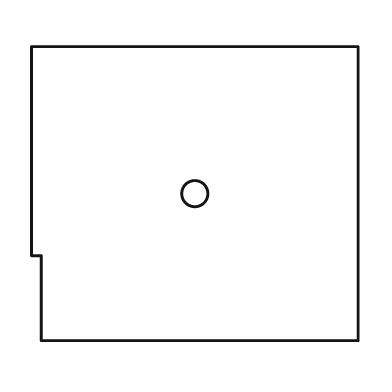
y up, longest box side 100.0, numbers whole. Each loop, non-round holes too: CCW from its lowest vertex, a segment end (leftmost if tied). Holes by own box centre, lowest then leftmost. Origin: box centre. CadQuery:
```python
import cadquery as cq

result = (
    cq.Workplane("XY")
    .moveTo(-47.0, -45.0)
    .lineTo(50.0, -45.0)
    .lineTo(50.0, 45.0)
    .lineTo(-50.0, 45.0)
    .lineTo(-50.0, -19.0)
    .lineTo(-47.0, -19.0)
    .close()
    .moveTo(0.0, 0.0)
    .circle(4.0)
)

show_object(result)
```